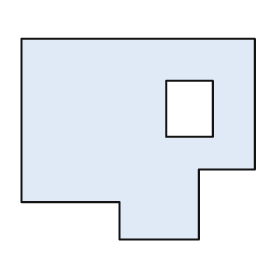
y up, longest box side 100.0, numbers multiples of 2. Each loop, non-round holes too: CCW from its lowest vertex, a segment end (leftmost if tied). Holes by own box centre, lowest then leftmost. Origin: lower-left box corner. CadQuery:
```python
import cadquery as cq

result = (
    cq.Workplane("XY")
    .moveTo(42.0, 0.0)
    .lineTo(76.0, 0.0)
    .lineTo(76.0, 30.0)
    .lineTo(100.0, 30.0)
    .lineTo(100.0, 86.0)
    .lineTo(0.0, 86.0)
    .lineTo(0.0, 16.0)
    .lineTo(42.0, 16.0)
    .close()
    .moveTo(62.0, 44.0)
    .lineTo(82.0, 44.0)
    .lineTo(82.0, 68.0)
    .lineTo(62.0, 68.0)
    .close()
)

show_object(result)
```